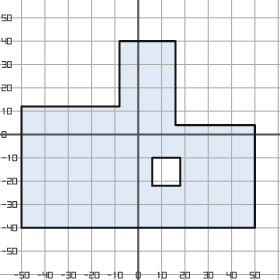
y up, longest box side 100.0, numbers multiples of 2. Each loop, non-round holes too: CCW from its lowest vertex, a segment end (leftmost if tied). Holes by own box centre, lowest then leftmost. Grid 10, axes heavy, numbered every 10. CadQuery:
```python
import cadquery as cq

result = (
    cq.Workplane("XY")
    .moveTo(-50.0, -40.0)
    .lineTo(50.0, -40.0)
    .lineTo(50.0, 4.0)
    .lineTo(16.0, 4.0)
    .lineTo(16.0, 40.0)
    .lineTo(-8.0, 40.0)
    .lineTo(-8.0, 12.0)
    .lineTo(-50.0, 12.0)
    .close()
    .moveTo(6.0, -22.0)
    .lineTo(18.0, -22.0)
    .lineTo(18.0, -10.0)
    .lineTo(6.0, -10.0)
    .close()
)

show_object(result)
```